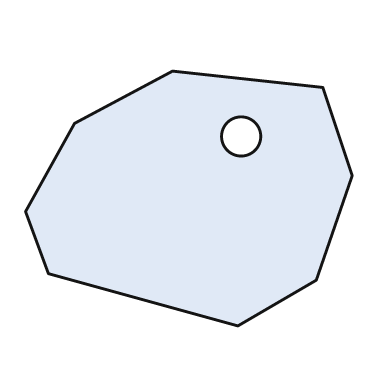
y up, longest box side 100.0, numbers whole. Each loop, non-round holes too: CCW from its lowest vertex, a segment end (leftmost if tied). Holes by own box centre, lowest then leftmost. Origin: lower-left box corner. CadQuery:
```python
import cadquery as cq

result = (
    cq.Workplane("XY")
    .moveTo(65.0, 0.0)
    .lineTo(89.0, 14.0)
    .lineTo(100.0, 46.0)
    .lineTo(91.0, 73.0)
    .lineTo(45.0, 78.0)
    .lineTo(15.0, 62.0)
    .lineTo(0.0, 35.0)
    .lineTo(7.0, 16.0)
    .close()
    .moveTo(66.0, 58.0)
    .circle(6.0)
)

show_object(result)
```